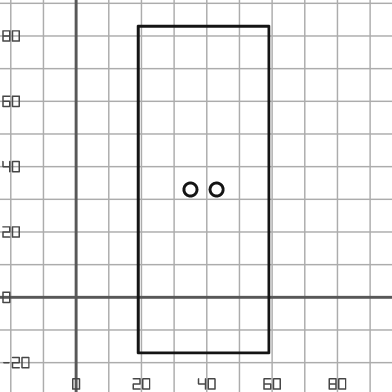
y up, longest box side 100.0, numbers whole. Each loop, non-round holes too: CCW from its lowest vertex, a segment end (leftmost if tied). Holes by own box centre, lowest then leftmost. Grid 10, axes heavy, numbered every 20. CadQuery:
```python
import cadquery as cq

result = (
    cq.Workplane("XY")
    .moveTo(19.0, -17.0)
    .lineTo(59.0, -17.0)
    .lineTo(59.0, 83.0)
    .lineTo(19.0, 83.0)
    .close()
    .moveTo(35.0, 33.0)
    .circle(2.0)
    .moveTo(43.0, 33.0)
    .circle(2.0)
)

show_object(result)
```